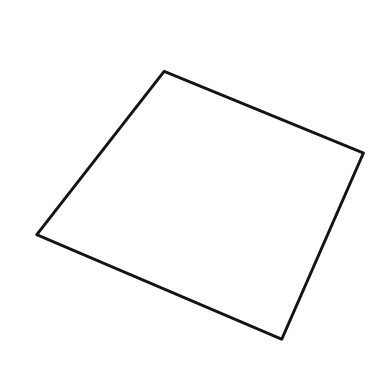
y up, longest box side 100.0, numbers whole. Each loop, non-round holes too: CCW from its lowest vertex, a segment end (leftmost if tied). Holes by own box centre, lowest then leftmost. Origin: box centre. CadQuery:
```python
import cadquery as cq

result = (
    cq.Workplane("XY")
    .moveTo(25.0, -41.0)
    .lineTo(50.0, 16.0)
    .lineTo(-11.0, 41.0)
    .lineTo(-50.0, -9.0)
    .close()
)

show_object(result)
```